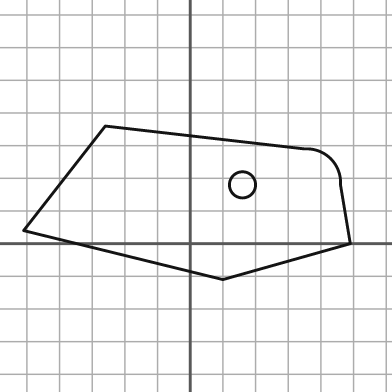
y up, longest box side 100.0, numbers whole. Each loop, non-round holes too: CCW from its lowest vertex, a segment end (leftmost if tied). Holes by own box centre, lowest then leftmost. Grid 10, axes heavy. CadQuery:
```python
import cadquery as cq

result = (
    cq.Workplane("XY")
    .moveTo(10.0, -11.0)
    .lineTo(49.0, 0.0)
    .lineTo(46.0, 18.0)
    .threePointArc((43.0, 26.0), (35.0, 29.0))
    .lineTo(-26.0, 36.0)
    .lineTo(-51.0, 4.0)
    .close()
    .moveTo(16.0, 18.0)
    .circle(4.0)
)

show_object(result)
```